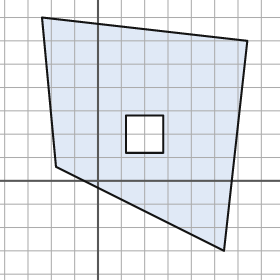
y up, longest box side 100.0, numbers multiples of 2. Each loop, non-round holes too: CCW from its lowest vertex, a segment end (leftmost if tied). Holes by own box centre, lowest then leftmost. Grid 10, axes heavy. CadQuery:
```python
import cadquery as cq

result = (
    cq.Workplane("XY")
    .moveTo(54.0, -30.0)
    .lineTo(64.0, 60.0)
    .lineTo(-24.0, 70.0)
    .lineTo(-18.0, 6.0)
    .close()
    .moveTo(12.0, 12.0)
    .lineTo(28.0, 12.0)
    .lineTo(28.0, 28.0)
    .lineTo(12.0, 28.0)
    .close()
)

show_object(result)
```